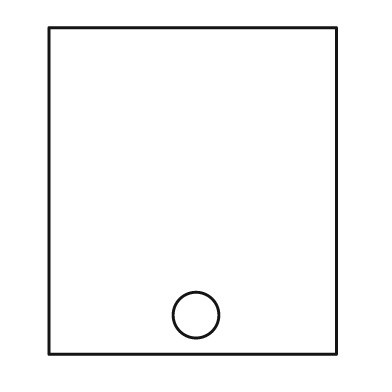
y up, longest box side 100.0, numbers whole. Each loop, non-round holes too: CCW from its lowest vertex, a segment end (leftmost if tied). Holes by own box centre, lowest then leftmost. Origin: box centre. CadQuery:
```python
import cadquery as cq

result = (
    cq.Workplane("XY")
    .moveTo(-44.0, -50.0)
    .lineTo(44.0, -50.0)
    .lineTo(44.0, 50.0)
    .lineTo(-44.0, 50.0)
    .close()
    .moveTo(1.0, -38.0)
    .circle(7.0)
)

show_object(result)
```